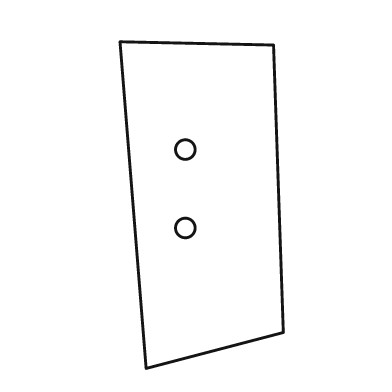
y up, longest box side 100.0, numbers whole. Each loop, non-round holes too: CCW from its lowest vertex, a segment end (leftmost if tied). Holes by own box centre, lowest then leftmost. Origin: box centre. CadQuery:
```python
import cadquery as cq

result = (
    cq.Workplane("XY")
    .moveTo(-17.0, -50.0)
    .lineTo(25.0, -39.0)
    .lineTo(22.0, 49.0)
    .lineTo(-25.0, 50.0)
    .close()
    .moveTo(-5.0, -7.0)
    .circle(3.0)
    .moveTo(-5.0, 17.0)
    .circle(3.0)
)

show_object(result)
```